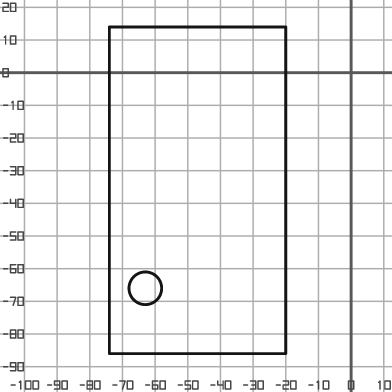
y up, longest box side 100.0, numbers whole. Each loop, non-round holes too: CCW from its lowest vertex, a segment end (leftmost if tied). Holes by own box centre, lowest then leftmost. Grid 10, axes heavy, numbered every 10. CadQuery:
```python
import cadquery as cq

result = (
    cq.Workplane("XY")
    .moveTo(-74.0, -86.0)
    .lineTo(-20.0, -86.0)
    .lineTo(-20.0, 14.0)
    .lineTo(-74.0, 14.0)
    .close()
    .moveTo(-63.0, -66.0)
    .circle(5.0)
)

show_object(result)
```